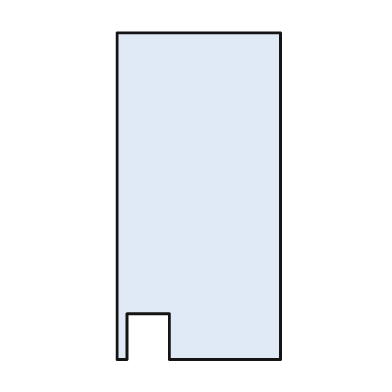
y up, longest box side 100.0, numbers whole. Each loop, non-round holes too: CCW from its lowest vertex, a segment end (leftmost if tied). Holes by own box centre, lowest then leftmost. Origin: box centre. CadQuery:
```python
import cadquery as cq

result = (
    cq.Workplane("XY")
    .moveTo(-25.0, -50.0)
    .lineTo(-22.0, -50.0)
    .lineTo(-22.0, -36.0)
    .lineTo(-9.0, -36.0)
    .lineTo(-9.0, -50.0)
    .lineTo(25.0, -50.0)
    .lineTo(25.0, 50.0)
    .lineTo(-25.0, 50.0)
    .close()
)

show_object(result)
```